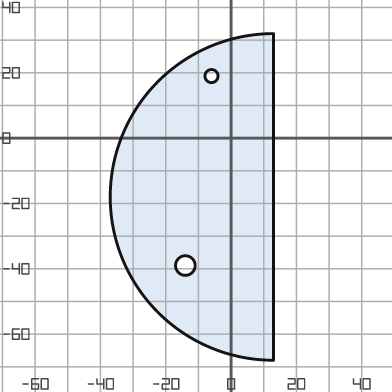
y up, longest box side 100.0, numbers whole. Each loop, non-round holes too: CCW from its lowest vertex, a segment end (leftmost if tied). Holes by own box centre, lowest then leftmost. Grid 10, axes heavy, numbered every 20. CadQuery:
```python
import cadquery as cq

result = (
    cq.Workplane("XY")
    .moveTo(13.0, -68.0)
    .lineTo(13.0, 32.0)
    .threePointArc((-37.0, -18.0), (13.0, -68.0))
    .close()
    .moveTo(-14.0, -39.0)
    .circle(3.0)
    .moveTo(-6.0, 19.0)
    .circle(2.0)
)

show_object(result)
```